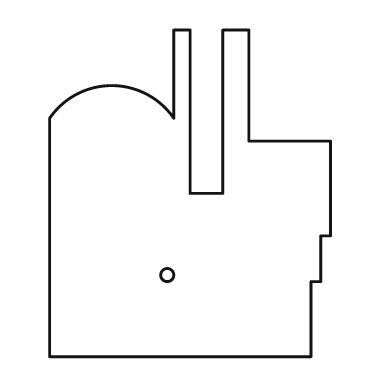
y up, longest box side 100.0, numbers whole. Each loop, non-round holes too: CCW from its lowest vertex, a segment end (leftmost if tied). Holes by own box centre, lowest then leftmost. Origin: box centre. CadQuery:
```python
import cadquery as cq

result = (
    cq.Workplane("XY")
    .moveTo(-43.0, -50.0)
    .lineTo(37.0, -50.0)
    .lineTo(37.0, -27.0)
    .lineTo(40.0, -27.0)
    .lineTo(40.0, -13.0)
    .lineTo(43.0, -13.0)
    .lineTo(43.0, 16.0)
    .lineTo(18.0, 16.0)
    .lineTo(18.0, 50.0)
    .lineTo(10.0, 50.0)
    .lineTo(10.0, 0.0)
    .lineTo(0.0, 0.0)
    .lineTo(0.0, 50.0)
    .lineTo(-5.0, 50.0)
    .lineTo(-5.0, 23.0)
    .threePointArc((-24.0, 33.0), (-43.0, 23.0))
    .close()
    .moveTo(-7.0, -25.0)
    .circle(2.0)
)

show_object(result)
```